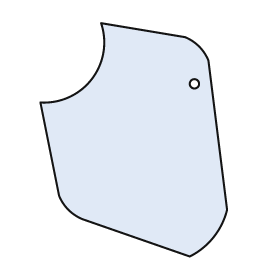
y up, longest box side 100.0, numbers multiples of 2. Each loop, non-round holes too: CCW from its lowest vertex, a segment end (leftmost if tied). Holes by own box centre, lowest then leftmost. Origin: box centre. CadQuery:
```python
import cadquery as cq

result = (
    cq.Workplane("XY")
    .moveTo(24.0, -50.0)
    .threePointArc((34.0, -42.0), (40.0, -30.0))
    .lineTo(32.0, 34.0)
    .threePointArc((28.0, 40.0), (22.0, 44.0))
    .lineTo(-14.0, 50.0)
    .threePointArc((-18.0, 26.0), (-40.0, 16.0))
    .lineTo(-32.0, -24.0)
    .threePointArc((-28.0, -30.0), (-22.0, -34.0))
    .close()
    .moveTo(26.0, 24.0)
    .circle(2.0)
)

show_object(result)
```